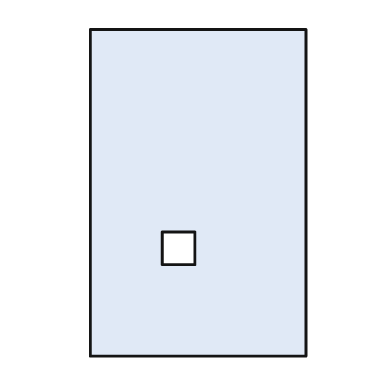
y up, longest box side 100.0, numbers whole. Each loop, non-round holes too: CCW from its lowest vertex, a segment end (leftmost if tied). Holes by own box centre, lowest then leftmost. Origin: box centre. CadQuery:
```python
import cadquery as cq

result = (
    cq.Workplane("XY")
    .moveTo(-33.0, -50.0)
    .lineTo(33.0, -50.0)
    .lineTo(33.0, 50.0)
    .lineTo(-33.0, 50.0)
    .close()
    .moveTo(-11.0, -22.0)
    .lineTo(-1.0, -22.0)
    .lineTo(-1.0, -12.0)
    .lineTo(-11.0, -12.0)
    .close()
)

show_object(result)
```